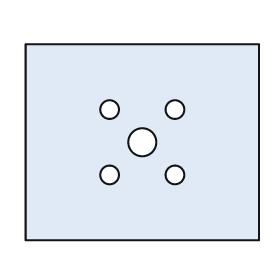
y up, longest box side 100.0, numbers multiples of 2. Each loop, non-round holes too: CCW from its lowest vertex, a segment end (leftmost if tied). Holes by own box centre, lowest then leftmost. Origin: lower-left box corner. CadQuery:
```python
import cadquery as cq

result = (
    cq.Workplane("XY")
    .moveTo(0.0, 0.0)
    .lineTo(100.0, 0.0)
    .lineTo(100.0, 84.0)
    .lineTo(0.0, 84.0)
    .close()
    .moveTo(36.0, 28.0)
    .circle(4.0)
    .moveTo(64.0, 28.0)
    .circle(4.0)
    .moveTo(50.0, 42.0)
    .circle(6.0)
    .moveTo(36.0, 56.0)
    .circle(4.0)
    .moveTo(64.0, 56.0)
    .circle(4.0)
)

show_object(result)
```